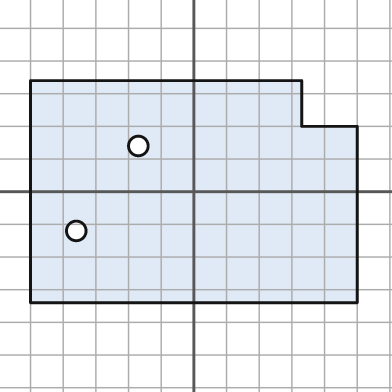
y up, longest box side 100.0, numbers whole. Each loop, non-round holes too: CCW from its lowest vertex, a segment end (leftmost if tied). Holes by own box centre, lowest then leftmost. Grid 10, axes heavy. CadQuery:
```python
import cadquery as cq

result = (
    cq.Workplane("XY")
    .moveTo(-50.0, -34.0)
    .lineTo(50.0, -34.0)
    .lineTo(50.0, 20.0)
    .lineTo(33.0, 20.0)
    .lineTo(33.0, 34.0)
    .lineTo(-50.0, 34.0)
    .close()
    .moveTo(-36.0, -12.0)
    .circle(3.0)
    .moveTo(-17.0, 14.0)
    .circle(3.0)
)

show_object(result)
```